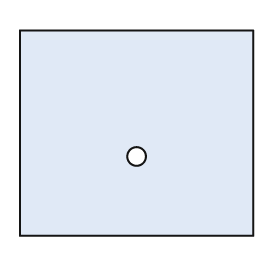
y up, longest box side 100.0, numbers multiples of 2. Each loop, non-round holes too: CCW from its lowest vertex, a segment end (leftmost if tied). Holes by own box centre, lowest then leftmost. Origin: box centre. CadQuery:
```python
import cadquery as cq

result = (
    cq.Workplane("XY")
    .moveTo(-50.0, -44.0)
    .lineTo(50.0, -44.0)
    .lineTo(50.0, 44.0)
    .lineTo(-50.0, 44.0)
    .close()
    .moveTo(0.0, -10.0)
    .circle(4.0)
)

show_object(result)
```